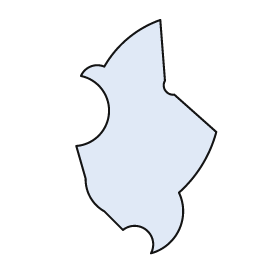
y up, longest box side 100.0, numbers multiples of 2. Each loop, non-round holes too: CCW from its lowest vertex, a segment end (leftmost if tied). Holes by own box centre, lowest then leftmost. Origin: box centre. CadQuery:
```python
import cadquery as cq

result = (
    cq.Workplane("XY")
    .moveTo(2.0, -50.0)
    .threePointArc((14.0, -40.0), (14.0, -24.0))
    .threePointArc((24.0, -12.0), (30.0, 2.0))
    .lineTo(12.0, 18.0)
    .threePointArc((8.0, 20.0), (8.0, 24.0))
    .lineTo(6.0, 50.0)
    .threePointArc((-8.0, 42.0), (-18.0, 30.0))
    .threePointArc((-24.0, 30.0), (-28.0, 26.0))
    .threePointArc((-16.0, 10.0), (-30.0, -4.0))
    .lineTo(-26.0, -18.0)
    .threePointArc((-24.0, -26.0), (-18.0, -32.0))
    .lineTo(-10.0, -40.0)
    .threePointArc((0.0, -40.0), (2.0, -50.0))
    .close()
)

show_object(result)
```